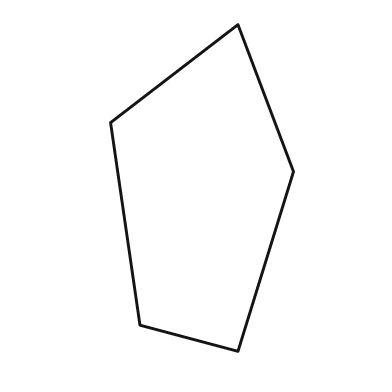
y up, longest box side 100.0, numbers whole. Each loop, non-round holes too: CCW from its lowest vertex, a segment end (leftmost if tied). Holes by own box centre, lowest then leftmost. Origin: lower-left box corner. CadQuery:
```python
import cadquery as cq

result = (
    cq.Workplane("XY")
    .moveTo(39.0, 0.0)
    .lineTo(56.0, 55.0)
    .lineTo(39.0, 100.0)
    .lineTo(0.0, 70.0)
    .lineTo(9.0, 8.0)
    .close()
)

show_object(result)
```